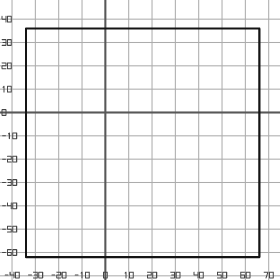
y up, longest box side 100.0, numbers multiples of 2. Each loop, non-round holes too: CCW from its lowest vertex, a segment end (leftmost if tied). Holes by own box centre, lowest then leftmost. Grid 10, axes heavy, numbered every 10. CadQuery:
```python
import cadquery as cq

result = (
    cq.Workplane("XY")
    .moveTo(-34.0, -62.0)
    .lineTo(66.0, -62.0)
    .lineTo(66.0, 36.0)
    .lineTo(-34.0, 36.0)
    .close()
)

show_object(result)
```